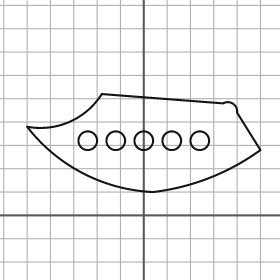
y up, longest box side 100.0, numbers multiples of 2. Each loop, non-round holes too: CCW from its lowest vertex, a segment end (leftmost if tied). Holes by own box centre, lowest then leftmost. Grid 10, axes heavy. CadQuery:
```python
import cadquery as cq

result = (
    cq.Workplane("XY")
    .moveTo(4.0, 10.0)
    .threePointArc((28.0, 16.0), (50.0, 28.0))
    .lineTo(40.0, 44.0)
    .threePointArc((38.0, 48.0), (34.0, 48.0))
    .lineTo(-18.0, 52.0)
    .threePointArc((-32.0, 40.0), (-50.0, 38.0))
    .threePointArc((-26.0, 18.0), (4.0, 10.0))
    .close()
    .moveTo(-24.0, 32.0)
    .circle(4.0)
    .moveTo(-12.0, 32.0)
    .circle(4.0)
    .moveTo(0.0, 32.0)
    .circle(4.0)
    .moveTo(12.0, 32.0)
    .circle(4.0)
    .moveTo(24.0, 32.0)
    .circle(4.0)
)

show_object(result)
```